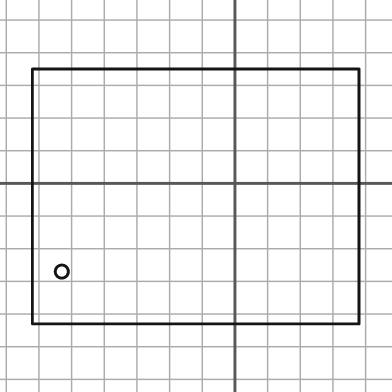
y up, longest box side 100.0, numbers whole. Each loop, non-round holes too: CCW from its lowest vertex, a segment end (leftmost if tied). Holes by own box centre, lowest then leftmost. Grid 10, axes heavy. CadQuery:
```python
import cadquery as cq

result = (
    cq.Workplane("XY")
    .moveTo(-62.0, -43.0)
    .lineTo(38.0, -43.0)
    .lineTo(38.0, 35.0)
    .lineTo(-62.0, 35.0)
    .close()
    .moveTo(-53.0, -27.0)
    .circle(2.0)
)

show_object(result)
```